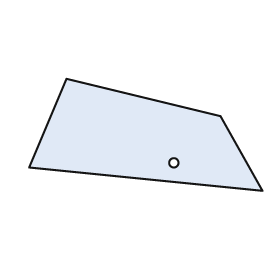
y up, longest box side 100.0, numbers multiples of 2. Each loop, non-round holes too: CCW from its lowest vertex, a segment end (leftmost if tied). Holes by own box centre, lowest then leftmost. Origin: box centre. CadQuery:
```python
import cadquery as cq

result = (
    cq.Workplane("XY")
    .moveTo(50.0, -24.0)
    .lineTo(32.0, 8.0)
    .lineTo(-34.0, 24.0)
    .lineTo(-50.0, -14.0)
    .close()
    .moveTo(12.0, -12.0)
    .circle(2.0)
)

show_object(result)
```